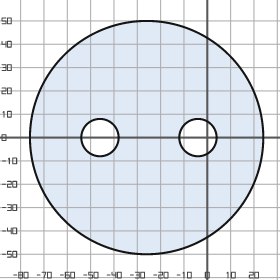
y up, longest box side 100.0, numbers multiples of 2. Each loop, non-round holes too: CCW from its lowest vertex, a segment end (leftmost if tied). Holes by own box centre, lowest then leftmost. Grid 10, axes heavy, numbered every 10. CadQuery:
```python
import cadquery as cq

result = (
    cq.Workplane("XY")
    .moveTo(-26.0, 0.0)
    .circle(50.0)
    .moveTo(-46.0, 0.0)
    .circle(8.0)
    .moveTo(-4.0, 0.0)
    .circle(8.0)
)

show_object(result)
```